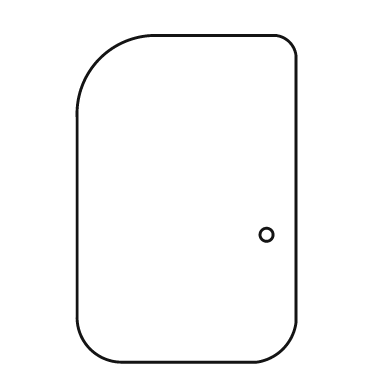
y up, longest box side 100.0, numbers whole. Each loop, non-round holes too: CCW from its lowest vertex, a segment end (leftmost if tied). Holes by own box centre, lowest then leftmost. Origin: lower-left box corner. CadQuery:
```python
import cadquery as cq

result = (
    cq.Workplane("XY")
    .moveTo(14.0, 0.0)
    .lineTo(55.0, 0.0)
    .threePointArc((63.0, 4.0), (67.0, 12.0))
    .lineTo(67.0, 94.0)
    .threePointArc((65.0, 98.0), (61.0, 100.0))
    .lineTo(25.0, 100.0)
    .threePointArc((7.0, 93.0), (0.0, 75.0))
    .lineTo(0.0, 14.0)
    .threePointArc((4.0, 4.0), (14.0, 0.0))
    .close()
    .moveTo(58.0, 39.0)
    .circle(2.0)
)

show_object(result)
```